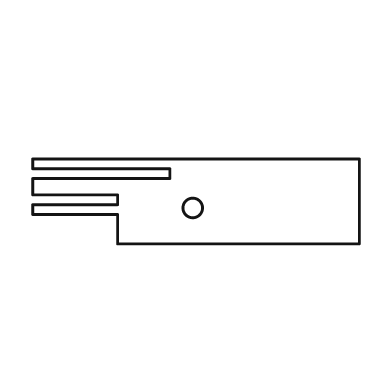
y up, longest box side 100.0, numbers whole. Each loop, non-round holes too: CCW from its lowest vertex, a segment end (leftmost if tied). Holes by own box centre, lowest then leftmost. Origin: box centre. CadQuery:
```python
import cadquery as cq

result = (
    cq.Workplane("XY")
    .moveTo(-24.0, -13.0)
    .lineTo(50.0, -13.0)
    .lineTo(50.0, 13.0)
    .lineTo(-50.0, 13.0)
    .lineTo(-50.0, 10.0)
    .lineTo(-8.0, 10.0)
    .lineTo(-8.0, 7.0)
    .lineTo(-50.0, 7.0)
    .lineTo(-50.0, 2.0)
    .lineTo(-24.0, 2.0)
    .lineTo(-24.0, -1.0)
    .lineTo(-50.0, -1.0)
    .lineTo(-50.0, -4.0)
    .lineTo(-24.0, -4.0)
    .close()
    .moveTo(-1.0, -2.0)
    .circle(3.0)
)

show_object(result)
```